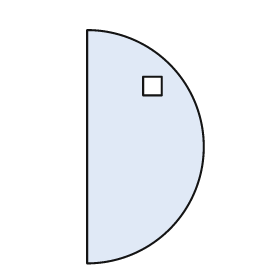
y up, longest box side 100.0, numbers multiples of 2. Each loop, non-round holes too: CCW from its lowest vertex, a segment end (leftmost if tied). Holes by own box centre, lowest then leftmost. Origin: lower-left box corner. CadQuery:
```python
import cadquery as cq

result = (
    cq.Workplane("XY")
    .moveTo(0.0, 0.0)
    .threePointArc((50.0, 50.0), (0.0, 100.0))
    .close()
    .moveTo(24.0, 72.0)
    .lineTo(32.0, 72.0)
    .lineTo(32.0, 80.0)
    .lineTo(24.0, 80.0)
    .close()
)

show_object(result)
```